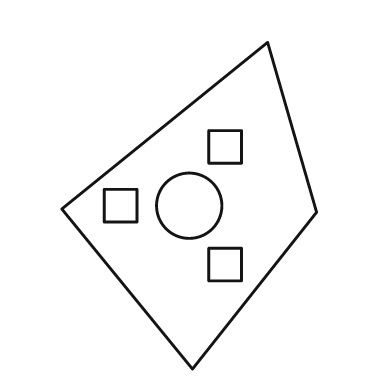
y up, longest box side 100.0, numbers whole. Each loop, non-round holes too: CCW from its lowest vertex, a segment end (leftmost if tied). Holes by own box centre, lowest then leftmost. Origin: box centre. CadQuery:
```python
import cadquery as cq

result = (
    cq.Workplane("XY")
    .moveTo(1.0, -50.0)
    .lineTo(39.0, -2.0)
    .lineTo(24.0, 50.0)
    .lineTo(-39.0, -1.0)
    .close()
    .moveTo(6.0, -23.0)
    .lineTo(16.0, -23.0)
    .lineTo(16.0, -13.0)
    .lineTo(6.0, -13.0)
    .close()
    .moveTo(-26.0, -5.0)
    .lineTo(-16.0, -5.0)
    .lineTo(-16.0, 5.0)
    .lineTo(-26.0, 5.0)
    .close()
    .moveTo(0.0, 0.0)
    .circle(10.0)
    .moveTo(6.0, 13.0)
    .lineTo(16.0, 13.0)
    .lineTo(16.0, 23.0)
    .lineTo(6.0, 23.0)
    .close()
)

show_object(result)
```